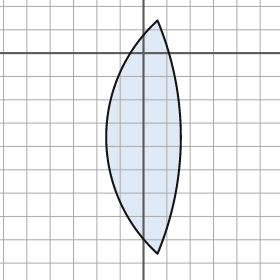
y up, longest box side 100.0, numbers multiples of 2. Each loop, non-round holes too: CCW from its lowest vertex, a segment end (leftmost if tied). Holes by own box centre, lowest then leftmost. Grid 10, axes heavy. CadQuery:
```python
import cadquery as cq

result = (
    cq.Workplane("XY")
    .moveTo(6.0, -86.0)
    .threePointArc((16.0, -36.0), (6.0, 14.0))
    .threePointArc((-16.0, -36.0), (6.0, -86.0))
    .close()
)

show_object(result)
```